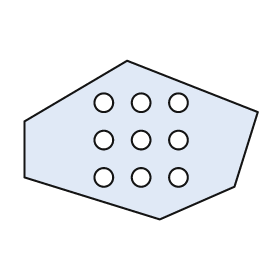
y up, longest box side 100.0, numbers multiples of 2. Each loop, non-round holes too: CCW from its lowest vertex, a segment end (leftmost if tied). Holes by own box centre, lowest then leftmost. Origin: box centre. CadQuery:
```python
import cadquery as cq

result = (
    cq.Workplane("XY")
    .moveTo(8.0, -34.0)
    .lineTo(40.0, -20.0)
    .lineTo(50.0, 12.0)
    .lineTo(-6.0, 34.0)
    .lineTo(-50.0, 8.0)
    .lineTo(-50.0, -16.0)
    .close()
    .moveTo(-16.0, -16.0)
    .circle(4.0)
    .moveTo(0.0, -16.0)
    .circle(4.0)
    .moveTo(16.0, -16.0)
    .circle(4.0)
    .moveTo(-16.0, 0.0)
    .circle(4.0)
    .moveTo(0.0, 0.0)
    .circle(4.0)
    .moveTo(16.0, 0.0)
    .circle(4.0)
    .moveTo(-16.0, 16.0)
    .circle(4.0)
    .moveTo(0.0, 16.0)
    .circle(4.0)
    .moveTo(16.0, 16.0)
    .circle(4.0)
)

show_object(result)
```